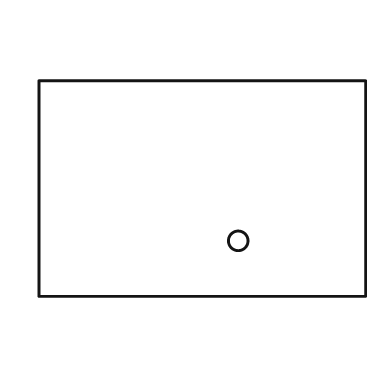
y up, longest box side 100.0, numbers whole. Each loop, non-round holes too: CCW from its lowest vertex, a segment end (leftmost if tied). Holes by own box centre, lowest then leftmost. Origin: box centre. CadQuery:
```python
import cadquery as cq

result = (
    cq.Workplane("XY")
    .moveTo(-50.0, -33.0)
    .lineTo(50.0, -33.0)
    .lineTo(50.0, 33.0)
    .lineTo(-50.0, 33.0)
    .close()
    .moveTo(11.0, -16.0)
    .circle(3.0)
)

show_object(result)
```